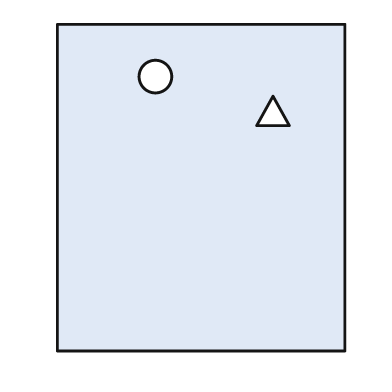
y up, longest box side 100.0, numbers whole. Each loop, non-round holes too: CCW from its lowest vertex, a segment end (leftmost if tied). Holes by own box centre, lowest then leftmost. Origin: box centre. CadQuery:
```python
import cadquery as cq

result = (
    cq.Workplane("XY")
    .moveTo(-44.0, -50.0)
    .lineTo(44.0, -50.0)
    .lineTo(44.0, 50.0)
    .lineTo(-44.0, 50.0)
    .close()
    .moveTo(17.0, 19.0)
    .lineTo(27.0, 19.0)
    .lineTo(22.0, 28.0)
    .close()
    .moveTo(-14.0, 34.0)
    .circle(5.0)
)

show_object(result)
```